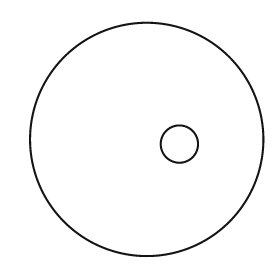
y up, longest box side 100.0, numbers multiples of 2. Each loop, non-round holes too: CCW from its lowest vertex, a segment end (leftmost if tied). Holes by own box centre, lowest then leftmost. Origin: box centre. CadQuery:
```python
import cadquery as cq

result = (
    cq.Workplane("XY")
    .moveTo(0.0, 0.0)
    .circle(50.0)
    .moveTo(14.0, -2.0)
    .circle(8.0)
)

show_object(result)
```